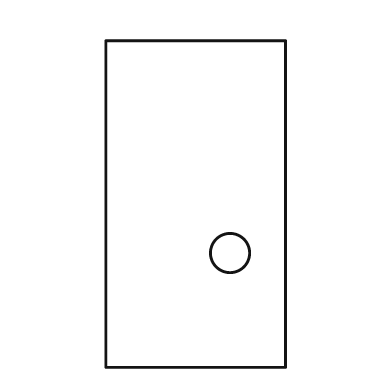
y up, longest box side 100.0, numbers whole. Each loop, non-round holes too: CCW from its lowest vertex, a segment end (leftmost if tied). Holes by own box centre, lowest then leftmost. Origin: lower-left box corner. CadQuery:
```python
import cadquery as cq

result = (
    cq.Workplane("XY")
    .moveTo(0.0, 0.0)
    .lineTo(55.0, 0.0)
    .lineTo(55.0, 100.0)
    .lineTo(0.0, 100.0)
    .close()
    .moveTo(38.0, 35.0)
    .circle(6.0)
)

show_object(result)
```